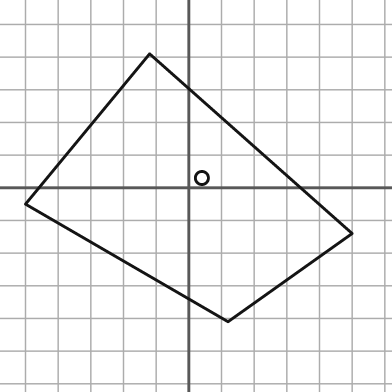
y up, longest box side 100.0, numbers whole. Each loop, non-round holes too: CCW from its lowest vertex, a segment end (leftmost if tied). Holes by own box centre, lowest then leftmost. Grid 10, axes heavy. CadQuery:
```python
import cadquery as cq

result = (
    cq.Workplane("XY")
    .moveTo(12.0, -41.0)
    .lineTo(50.0, -14.0)
    .lineTo(-12.0, 41.0)
    .lineTo(-50.0, -5.0)
    .close()
    .moveTo(4.0, 3.0)
    .circle(2.0)
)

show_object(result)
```